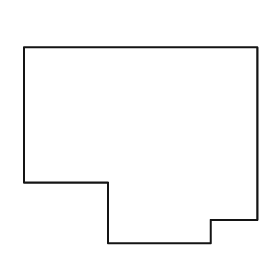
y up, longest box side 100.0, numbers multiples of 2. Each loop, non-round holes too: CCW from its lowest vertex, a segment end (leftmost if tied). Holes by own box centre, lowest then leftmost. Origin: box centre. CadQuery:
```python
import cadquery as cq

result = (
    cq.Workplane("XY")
    .moveTo(-14.0, -42.0)
    .lineTo(30.0, -42.0)
    .lineTo(30.0, -32.0)
    .lineTo(50.0, -32.0)
    .lineTo(50.0, 42.0)
    .lineTo(-50.0, 42.0)
    .lineTo(-50.0, -16.0)
    .lineTo(-14.0, -16.0)
    .close()
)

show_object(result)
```